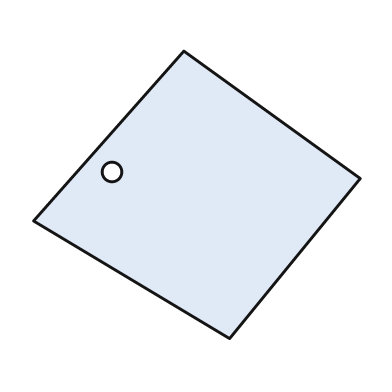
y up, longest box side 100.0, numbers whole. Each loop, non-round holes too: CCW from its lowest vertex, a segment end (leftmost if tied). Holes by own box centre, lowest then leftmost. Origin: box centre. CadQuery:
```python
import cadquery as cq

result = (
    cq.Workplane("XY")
    .moveTo(10.0, -44.0)
    .lineTo(50.0, 5.0)
    .lineTo(-4.0, 44.0)
    .lineTo(-50.0, -8.0)
    .close()
    .moveTo(-26.0, 7.0)
    .circle(3.0)
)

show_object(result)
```